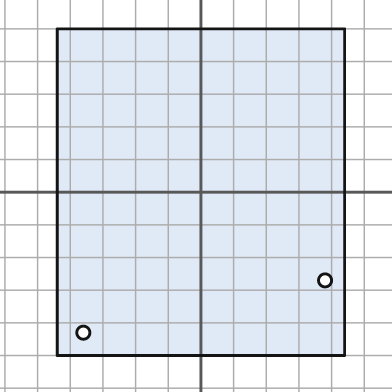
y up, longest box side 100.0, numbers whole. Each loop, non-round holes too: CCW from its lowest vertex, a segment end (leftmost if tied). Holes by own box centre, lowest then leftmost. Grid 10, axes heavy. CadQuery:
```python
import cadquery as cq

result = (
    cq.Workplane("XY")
    .moveTo(-44.0, -50.0)
    .lineTo(44.0, -50.0)
    .lineTo(44.0, 50.0)
    .lineTo(-44.0, 50.0)
    .close()
    .moveTo(-36.0, -43.0)
    .circle(2.0)
    .moveTo(38.0, -27.0)
    .circle(2.0)
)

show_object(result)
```